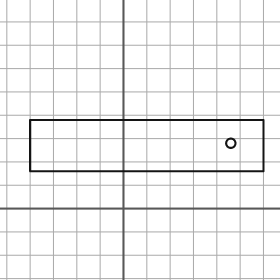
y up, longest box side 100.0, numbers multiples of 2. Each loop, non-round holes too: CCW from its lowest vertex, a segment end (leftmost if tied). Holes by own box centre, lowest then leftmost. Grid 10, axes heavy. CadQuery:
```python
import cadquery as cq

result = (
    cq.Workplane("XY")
    .moveTo(-40.0, 16.0)
    .lineTo(60.0, 16.0)
    .lineTo(60.0, 38.0)
    .lineTo(-40.0, 38.0)
    .close()
    .moveTo(46.0, 28.0)
    .circle(2.0)
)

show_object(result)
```